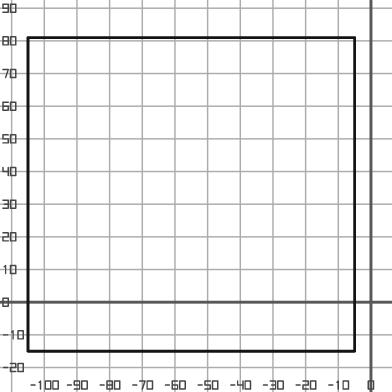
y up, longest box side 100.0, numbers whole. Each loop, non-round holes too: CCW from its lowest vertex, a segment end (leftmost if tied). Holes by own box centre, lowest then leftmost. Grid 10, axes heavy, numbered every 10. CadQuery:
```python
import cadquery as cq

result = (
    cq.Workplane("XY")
    .moveTo(-105.0, -15.0)
    .lineTo(-5.0, -15.0)
    .lineTo(-5.0, 81.0)
    .lineTo(-105.0, 81.0)
    .close()
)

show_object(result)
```